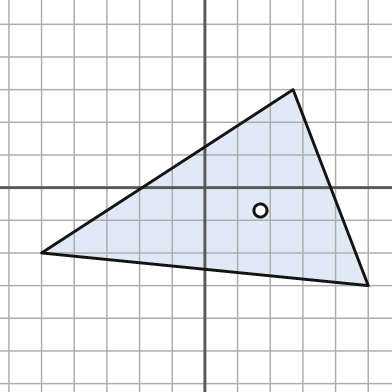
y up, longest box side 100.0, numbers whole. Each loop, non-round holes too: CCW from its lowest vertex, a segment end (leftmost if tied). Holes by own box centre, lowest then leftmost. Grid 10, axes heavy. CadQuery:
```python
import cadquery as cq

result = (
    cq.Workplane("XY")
    .moveTo(50.0, -30.0)
    .lineTo(27.0, 30.0)
    .lineTo(-50.0, -20.0)
    .close()
    .moveTo(17.0, -7.0)
    .circle(2.0)
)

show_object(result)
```